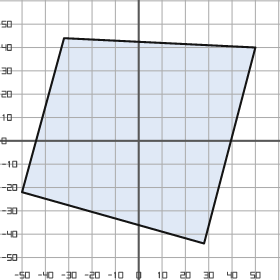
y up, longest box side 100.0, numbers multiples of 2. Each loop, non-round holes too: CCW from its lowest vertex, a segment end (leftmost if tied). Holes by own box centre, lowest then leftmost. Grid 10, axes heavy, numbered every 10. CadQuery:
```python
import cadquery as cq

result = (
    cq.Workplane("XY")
    .moveTo(28.0, -44.0)
    .lineTo(50.0, 40.0)
    .lineTo(-32.0, 44.0)
    .lineTo(-50.0, -22.0)
    .close()
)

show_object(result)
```